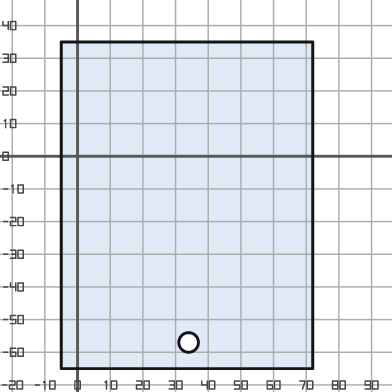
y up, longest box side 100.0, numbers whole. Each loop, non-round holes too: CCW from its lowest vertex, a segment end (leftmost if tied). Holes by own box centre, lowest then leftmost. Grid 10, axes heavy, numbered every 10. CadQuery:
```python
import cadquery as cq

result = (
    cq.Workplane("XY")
    .moveTo(-5.0, -65.0)
    .lineTo(72.0, -65.0)
    .lineTo(72.0, 35.0)
    .lineTo(-5.0, 35.0)
    .close()
    .moveTo(34.0, -57.0)
    .circle(3.0)
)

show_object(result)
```